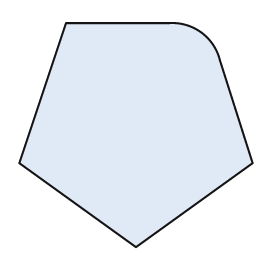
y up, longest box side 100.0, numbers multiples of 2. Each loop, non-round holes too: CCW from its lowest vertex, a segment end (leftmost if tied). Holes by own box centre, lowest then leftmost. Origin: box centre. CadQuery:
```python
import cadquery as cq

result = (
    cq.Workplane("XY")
    .moveTo(0.0, -48.0)
    .lineTo(50.0, -12.0)
    .lineTo(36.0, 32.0)
    .threePointArc((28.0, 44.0), (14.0, 48.0))
    .lineTo(-30.0, 48.0)
    .lineTo(-50.0, -12.0)
    .close()
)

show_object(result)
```